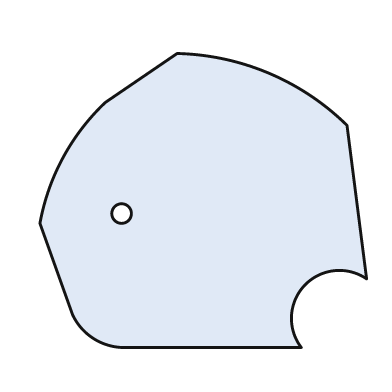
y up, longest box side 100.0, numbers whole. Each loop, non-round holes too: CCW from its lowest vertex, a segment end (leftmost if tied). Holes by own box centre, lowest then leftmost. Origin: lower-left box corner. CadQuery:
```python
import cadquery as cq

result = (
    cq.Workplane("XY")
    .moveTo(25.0, 0.0)
    .lineTo(80.0, 0.0)
    .threePointArc((81.0, 19.0), (100.0, 21.0))
    .lineTo(94.0, 68.0)
    .threePointArc((70.0, 84.0), (42.0, 90.0))
    .lineTo(20.0, 75.0)
    .threePointArc((7.0, 58.0), (0.0, 38.0))
    .lineTo(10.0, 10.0)
    .threePointArc((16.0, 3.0), (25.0, 0.0))
    .close()
    .moveTo(25.0, 41.0)
    .circle(3.0)
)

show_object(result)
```